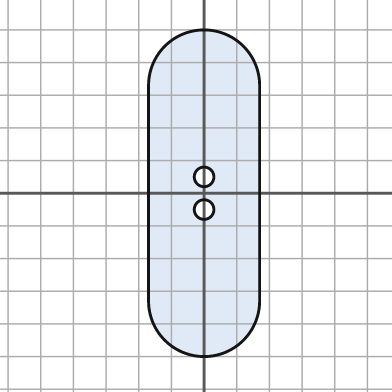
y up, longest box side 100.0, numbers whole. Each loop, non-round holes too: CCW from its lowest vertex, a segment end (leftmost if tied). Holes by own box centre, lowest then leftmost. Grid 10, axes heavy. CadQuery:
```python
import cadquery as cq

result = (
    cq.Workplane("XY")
    .moveTo(-17.0, -33.0)
    .threePointArc((0.0, -50.0), (17.0, -33.0))
    .lineTo(17.0, 33.0)
    .threePointArc((0.0, 50.0), (-17.0, 33.0))
    .close()
    .moveTo(0.0, -5.0)
    .circle(3.0)
    .moveTo(0.0, 5.0)
    .circle(3.0)
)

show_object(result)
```